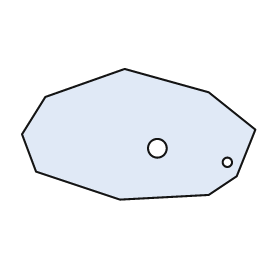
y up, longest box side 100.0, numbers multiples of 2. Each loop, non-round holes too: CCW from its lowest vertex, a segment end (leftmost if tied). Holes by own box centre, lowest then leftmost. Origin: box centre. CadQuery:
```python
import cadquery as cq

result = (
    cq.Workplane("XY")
    .moveTo(-8.0, -28.0)
    .lineTo(30.0, -26.0)
    .lineTo(42.0, -18.0)
    .lineTo(50.0, 2.0)
    .lineTo(30.0, 18.0)
    .lineTo(-6.0, 28.0)
    .lineTo(-40.0, 16.0)
    .lineTo(-50.0, 0.0)
    .lineTo(-44.0, -16.0)
    .close()
    .moveTo(38.0, -12.0)
    .circle(2.0)
    .moveTo(8.0, -6.0)
    .circle(4.0)
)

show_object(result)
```